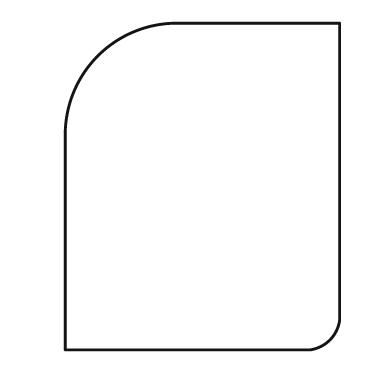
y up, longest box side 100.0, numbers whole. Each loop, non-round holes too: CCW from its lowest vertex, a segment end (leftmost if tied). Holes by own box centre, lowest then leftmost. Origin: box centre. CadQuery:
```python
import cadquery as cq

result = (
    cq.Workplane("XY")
    .moveTo(-42.0, -50.0)
    .lineTo(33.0, -50.0)
    .threePointArc((39.0, -47.0), (42.0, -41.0))
    .lineTo(42.0, 50.0)
    .lineTo(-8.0, 50.0)
    .threePointArc((-32.0, 40.0), (-42.0, 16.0))
    .close()
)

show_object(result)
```